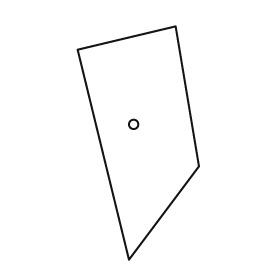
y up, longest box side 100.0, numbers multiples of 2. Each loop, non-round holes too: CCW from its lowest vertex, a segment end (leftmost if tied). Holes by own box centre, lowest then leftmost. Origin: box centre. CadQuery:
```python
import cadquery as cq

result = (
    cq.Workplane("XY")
    .moveTo(-4.0, -50.0)
    .lineTo(26.0, -10.0)
    .lineTo(16.0, 50.0)
    .lineTo(-26.0, 40.0)
    .close()
    .moveTo(-2.0, 8.0)
    .circle(2.0)
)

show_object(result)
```